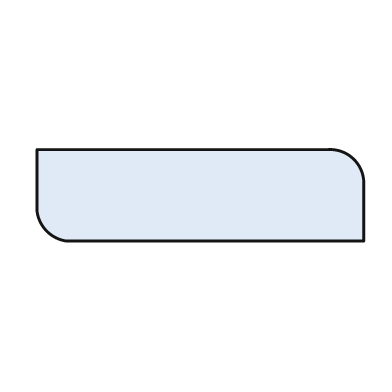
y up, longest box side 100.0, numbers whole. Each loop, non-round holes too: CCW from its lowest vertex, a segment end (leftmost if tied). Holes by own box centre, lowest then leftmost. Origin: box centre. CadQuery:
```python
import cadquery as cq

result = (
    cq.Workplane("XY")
    .moveTo(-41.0, -14.0)
    .lineTo(50.0, -14.0)
    .lineTo(50.0, 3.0)
    .threePointArc((47.0, 11.0), (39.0, 14.0))
    .lineTo(-50.0, 14.0)
    .lineTo(-50.0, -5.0)
    .threePointArc((-47.0, -11.0), (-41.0, -14.0))
    .close()
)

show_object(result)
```